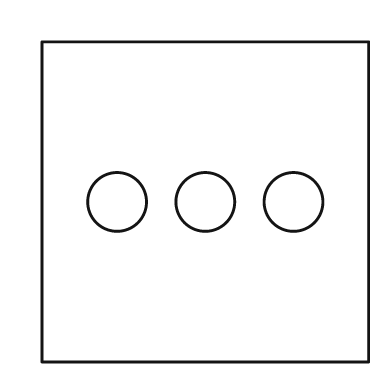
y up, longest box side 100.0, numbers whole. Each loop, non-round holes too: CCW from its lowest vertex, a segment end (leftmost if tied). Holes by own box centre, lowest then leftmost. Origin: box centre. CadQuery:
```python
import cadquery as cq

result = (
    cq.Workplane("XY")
    .moveTo(-50.0, -49.0)
    .lineTo(50.0, -49.0)
    .lineTo(50.0, 49.0)
    .lineTo(-50.0, 49.0)
    .close()
    .moveTo(-27.0, 0.0)
    .circle(9.0)
    .moveTo(0.0, 0.0)
    .circle(9.0)
    .moveTo(27.0, 0.0)
    .circle(9.0)
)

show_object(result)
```